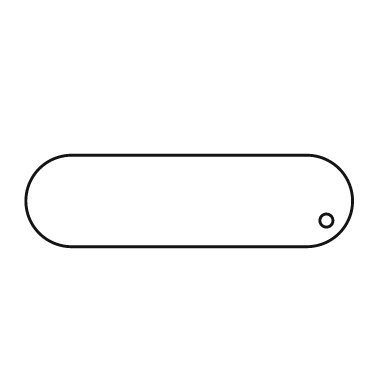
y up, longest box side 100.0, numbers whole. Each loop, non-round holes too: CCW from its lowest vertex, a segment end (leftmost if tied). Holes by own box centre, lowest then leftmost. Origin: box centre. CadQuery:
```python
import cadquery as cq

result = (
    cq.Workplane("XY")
    .moveTo(-36.0, -14.0)
    .lineTo(36.0, -14.0)
    .threePointArc((50.0, 0.0), (36.0, 14.0))
    .lineTo(-36.0, 14.0)
    .threePointArc((-50.0, 0.0), (-36.0, -14.0))
    .close()
    .moveTo(42.0, -6.0)
    .circle(2.0)
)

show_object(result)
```